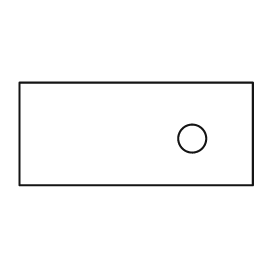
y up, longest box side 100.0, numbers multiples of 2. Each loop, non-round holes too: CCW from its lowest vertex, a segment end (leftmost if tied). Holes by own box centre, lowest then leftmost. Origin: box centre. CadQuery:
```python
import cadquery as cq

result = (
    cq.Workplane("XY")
    .moveTo(-50.0, -22.0)
    .lineTo(50.0, -22.0)
    .lineTo(50.0, 22.0)
    .lineTo(-50.0, 22.0)
    .close()
    .moveTo(24.0, -2.0)
    .circle(6.0)
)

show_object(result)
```